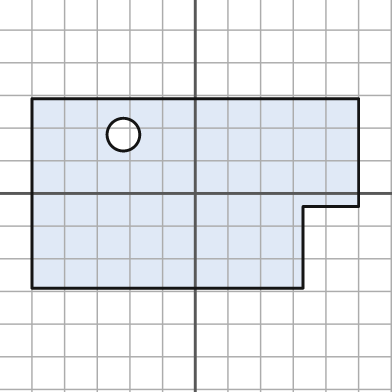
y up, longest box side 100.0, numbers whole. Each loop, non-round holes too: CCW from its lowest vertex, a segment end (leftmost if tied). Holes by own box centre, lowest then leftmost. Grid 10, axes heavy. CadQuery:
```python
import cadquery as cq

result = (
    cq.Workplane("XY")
    .moveTo(-50.0, -29.0)
    .lineTo(33.0, -29.0)
    .lineTo(33.0, -4.0)
    .lineTo(50.0, -4.0)
    .lineTo(50.0, 29.0)
    .lineTo(-50.0, 29.0)
    .close()
    .moveTo(-22.0, 18.0)
    .circle(5.0)
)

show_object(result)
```